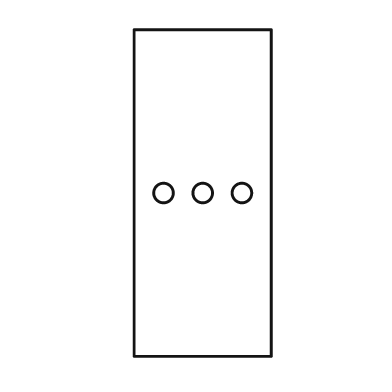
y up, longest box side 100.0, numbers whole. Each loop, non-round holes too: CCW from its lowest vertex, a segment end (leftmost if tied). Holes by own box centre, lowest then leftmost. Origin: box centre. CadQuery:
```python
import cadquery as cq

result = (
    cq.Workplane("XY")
    .moveTo(-21.0, -50.0)
    .lineTo(21.0, -50.0)
    .lineTo(21.0, 50.0)
    .lineTo(-21.0, 50.0)
    .close()
    .moveTo(-12.0, 0.0)
    .circle(3.0)
    .moveTo(0.0, 0.0)
    .circle(3.0)
    .moveTo(12.0, 0.0)
    .circle(3.0)
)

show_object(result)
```